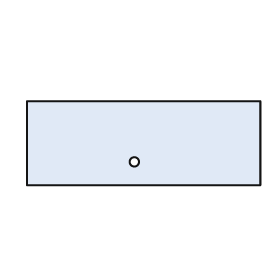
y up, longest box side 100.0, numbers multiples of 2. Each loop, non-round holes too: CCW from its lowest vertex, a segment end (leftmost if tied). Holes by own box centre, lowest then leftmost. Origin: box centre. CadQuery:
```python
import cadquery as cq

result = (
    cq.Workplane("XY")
    .moveTo(-50.0, -18.0)
    .lineTo(50.0, -18.0)
    .lineTo(50.0, 18.0)
    .lineTo(-50.0, 18.0)
    .close()
    .moveTo(-4.0, -8.0)
    .circle(2.0)
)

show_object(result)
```